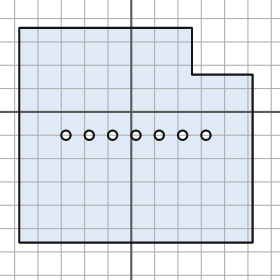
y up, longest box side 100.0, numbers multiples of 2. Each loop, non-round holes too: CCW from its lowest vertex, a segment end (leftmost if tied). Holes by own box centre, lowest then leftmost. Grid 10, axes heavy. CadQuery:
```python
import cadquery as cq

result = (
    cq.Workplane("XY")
    .moveTo(-48.0, -56.0)
    .lineTo(52.0, -56.0)
    .lineTo(52.0, 16.0)
    .lineTo(26.0, 16.0)
    .lineTo(26.0, 36.0)
    .lineTo(-48.0, 36.0)
    .close()
    .moveTo(-28.0, -10.0)
    .circle(2.0)
    .moveTo(-18.0, -10.0)
    .circle(2.0)
    .moveTo(-8.0, -10.0)
    .circle(2.0)
    .moveTo(2.0, -10.0)
    .circle(2.0)
    .moveTo(12.0, -10.0)
    .circle(2.0)
    .moveTo(22.0, -10.0)
    .circle(2.0)
    .moveTo(32.0, -10.0)
    .circle(2.0)
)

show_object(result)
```